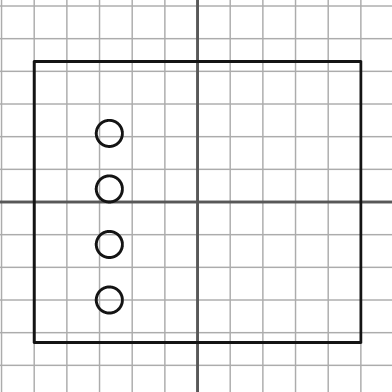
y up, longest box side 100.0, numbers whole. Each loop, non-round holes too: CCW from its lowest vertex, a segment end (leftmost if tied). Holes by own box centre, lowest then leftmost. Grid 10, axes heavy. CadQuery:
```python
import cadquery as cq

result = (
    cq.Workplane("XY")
    .moveTo(-50.0, -43.0)
    .lineTo(50.0, -43.0)
    .lineTo(50.0, 43.0)
    .lineTo(-50.0, 43.0)
    .close()
    .moveTo(-27.0, -30.0)
    .circle(4.0)
    .moveTo(-27.0, -13.0)
    .circle(4.0)
    .moveTo(-27.0, 4.0)
    .circle(4.0)
    .moveTo(-27.0, 21.0)
    .circle(4.0)
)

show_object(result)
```